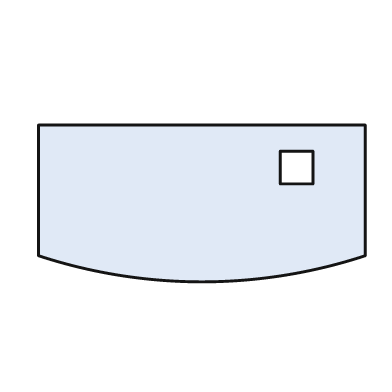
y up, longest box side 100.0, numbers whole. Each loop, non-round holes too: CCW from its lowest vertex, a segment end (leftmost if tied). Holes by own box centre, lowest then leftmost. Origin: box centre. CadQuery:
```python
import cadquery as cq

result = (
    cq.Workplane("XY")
    .moveTo(-50.0, -16.0)
    .threePointArc((0.0, -24.0), (50.0, -16.0))
    .lineTo(50.0, 24.0)
    .lineTo(-50.0, 24.0)
    .close()
    .moveTo(24.0, 6.0)
    .lineTo(34.0, 6.0)
    .lineTo(34.0, 16.0)
    .lineTo(24.0, 16.0)
    .close()
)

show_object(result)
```